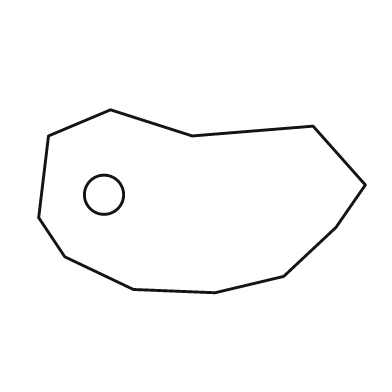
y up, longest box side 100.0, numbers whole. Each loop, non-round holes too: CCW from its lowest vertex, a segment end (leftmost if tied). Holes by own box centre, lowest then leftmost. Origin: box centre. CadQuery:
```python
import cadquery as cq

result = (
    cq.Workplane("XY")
    .moveTo(4.0, -28.0)
    .lineTo(25.0, -23.0)
    .lineTo(41.0, -8.0)
    .lineTo(50.0, 5.0)
    .lineTo(34.0, 23.0)
    .lineTo(-3.0, 20.0)
    .lineTo(-28.0, 28.0)
    .lineTo(-47.0, 20.0)
    .lineTo(-50.0, -5.0)
    .lineTo(-42.0, -17.0)
    .lineTo(-21.0, -27.0)
    .close()
    .moveTo(-30.0, 2.0)
    .circle(6.0)
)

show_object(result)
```